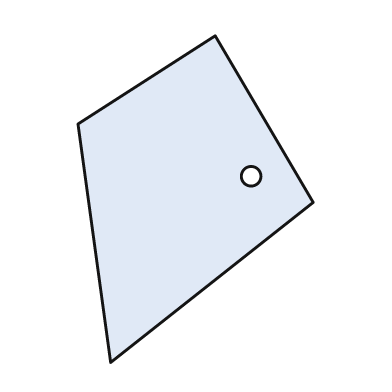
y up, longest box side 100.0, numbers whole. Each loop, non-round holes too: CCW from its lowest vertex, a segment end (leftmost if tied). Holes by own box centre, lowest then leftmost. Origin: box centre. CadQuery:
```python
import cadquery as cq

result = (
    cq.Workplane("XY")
    .moveTo(-26.0, -50.0)
    .lineTo(36.0, -1.0)
    .lineTo(6.0, 50.0)
    .lineTo(-36.0, 23.0)
    .close()
    .moveTo(17.0, 7.0)
    .circle(3.0)
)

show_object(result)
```